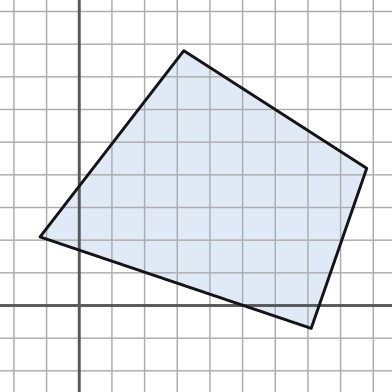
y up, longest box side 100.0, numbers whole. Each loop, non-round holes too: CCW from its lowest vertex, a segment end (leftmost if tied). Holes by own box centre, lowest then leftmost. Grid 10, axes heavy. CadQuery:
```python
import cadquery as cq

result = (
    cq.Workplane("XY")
    .moveTo(71.0, -7.0)
    .lineTo(88.0, 42.0)
    .lineTo(32.0, 78.0)
    .lineTo(-12.0, 21.0)
    .close()
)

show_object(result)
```